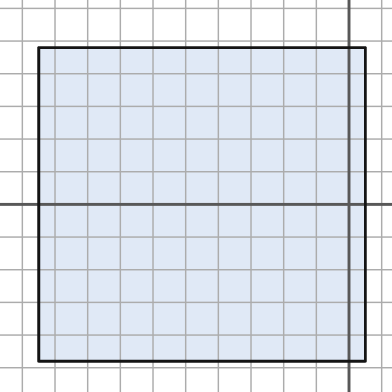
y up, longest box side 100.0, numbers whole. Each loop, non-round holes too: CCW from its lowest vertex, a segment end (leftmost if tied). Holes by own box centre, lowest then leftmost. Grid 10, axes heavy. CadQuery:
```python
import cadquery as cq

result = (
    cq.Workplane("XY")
    .moveTo(-95.0, -48.0)
    .lineTo(5.0, -48.0)
    .lineTo(5.0, 48.0)
    .lineTo(-95.0, 48.0)
    .close()
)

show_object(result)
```